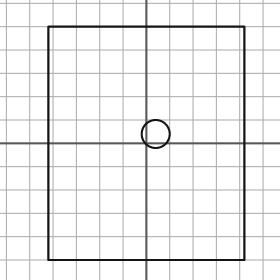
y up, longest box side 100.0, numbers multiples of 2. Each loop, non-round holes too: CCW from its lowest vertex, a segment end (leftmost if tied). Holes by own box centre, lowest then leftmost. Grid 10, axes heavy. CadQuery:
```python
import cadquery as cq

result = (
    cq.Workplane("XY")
    .moveTo(-42.0, -50.0)
    .lineTo(42.0, -50.0)
    .lineTo(42.0, 50.0)
    .lineTo(-42.0, 50.0)
    .close()
    .moveTo(4.0, 4.0)
    .circle(6.0)
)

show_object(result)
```